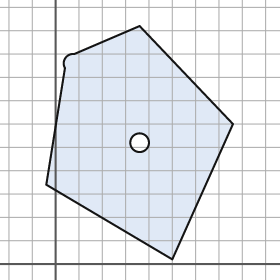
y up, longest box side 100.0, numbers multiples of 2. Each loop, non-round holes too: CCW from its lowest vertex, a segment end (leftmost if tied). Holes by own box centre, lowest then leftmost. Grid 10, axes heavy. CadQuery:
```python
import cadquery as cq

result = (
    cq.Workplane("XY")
    .moveTo(50.0, 2.0)
    .lineTo(76.0, 60.0)
    .lineTo(36.0, 102.0)
    .lineTo(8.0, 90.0)
    .threePointArc((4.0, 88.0), (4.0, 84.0))
    .lineTo(-4.0, 34.0)
    .close()
    .moveTo(36.0, 52.0)
    .circle(4.0)
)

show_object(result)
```